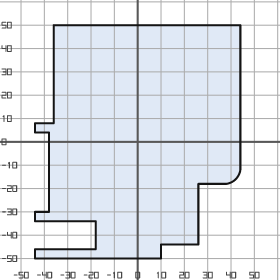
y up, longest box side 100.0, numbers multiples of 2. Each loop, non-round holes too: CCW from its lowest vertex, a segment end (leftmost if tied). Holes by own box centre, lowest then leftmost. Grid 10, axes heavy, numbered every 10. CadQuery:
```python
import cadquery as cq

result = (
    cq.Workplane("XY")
    .moveTo(-44.0, -50.0)
    .lineTo(10.0, -50.0)
    .lineTo(10.0, -44.0)
    .lineTo(26.0, -44.0)
    .lineTo(26.0, -18.0)
    .lineTo(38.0, -18.0)
    .threePointArc((42.0, -16.0), (44.0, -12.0))
    .lineTo(44.0, 50.0)
    .lineTo(-36.0, 50.0)
    .lineTo(-36.0, 8.0)
    .lineTo(-44.0, 8.0)
    .lineTo(-44.0, 4.0)
    .lineTo(-38.0, 4.0)
    .lineTo(-38.0, -30.0)
    .lineTo(-44.0, -30.0)
    .lineTo(-44.0, -34.0)
    .lineTo(-18.0, -34.0)
    .lineTo(-18.0, -46.0)
    .lineTo(-44.0, -46.0)
    .close()
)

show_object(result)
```